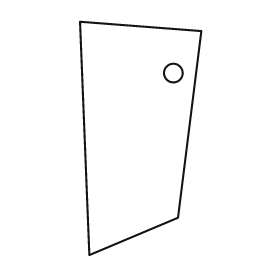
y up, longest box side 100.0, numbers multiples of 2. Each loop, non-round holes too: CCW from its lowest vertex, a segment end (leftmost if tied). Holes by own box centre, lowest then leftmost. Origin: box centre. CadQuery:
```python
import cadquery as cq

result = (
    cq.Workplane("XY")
    .moveTo(-22.0, -50.0)
    .lineTo(16.0, -34.0)
    .lineTo(26.0, 46.0)
    .lineTo(-26.0, 50.0)
    .close()
    .moveTo(14.0, 28.0)
    .circle(4.0)
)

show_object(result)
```